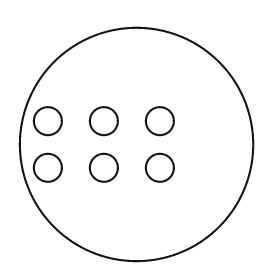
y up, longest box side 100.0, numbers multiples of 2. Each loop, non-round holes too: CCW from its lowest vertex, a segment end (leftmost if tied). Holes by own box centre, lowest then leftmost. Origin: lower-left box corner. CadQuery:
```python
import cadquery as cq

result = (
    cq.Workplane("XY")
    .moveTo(50.0, 50.0)
    .circle(50.0)
    .moveTo(12.0, 40.0)
    .circle(6.0)
    .moveTo(36.0, 40.0)
    .circle(6.0)
    .moveTo(60.0, 40.0)
    .circle(6.0)
    .moveTo(12.0, 60.0)
    .circle(6.0)
    .moveTo(36.0, 60.0)
    .circle(6.0)
    .moveTo(60.0, 60.0)
    .circle(6.0)
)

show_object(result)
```